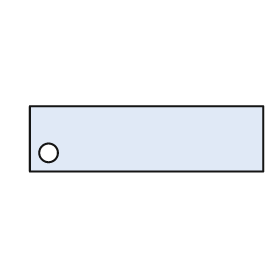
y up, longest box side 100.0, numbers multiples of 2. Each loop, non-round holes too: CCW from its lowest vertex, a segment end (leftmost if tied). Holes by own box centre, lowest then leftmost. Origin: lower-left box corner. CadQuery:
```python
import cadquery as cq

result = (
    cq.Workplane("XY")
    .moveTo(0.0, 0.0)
    .lineTo(100.0, 0.0)
    .lineTo(100.0, 28.0)
    .lineTo(0.0, 28.0)
    .close()
    .moveTo(8.0, 8.0)
    .circle(4.0)
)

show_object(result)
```